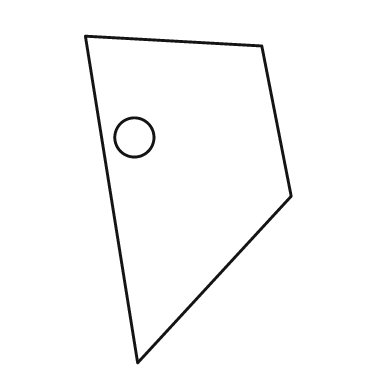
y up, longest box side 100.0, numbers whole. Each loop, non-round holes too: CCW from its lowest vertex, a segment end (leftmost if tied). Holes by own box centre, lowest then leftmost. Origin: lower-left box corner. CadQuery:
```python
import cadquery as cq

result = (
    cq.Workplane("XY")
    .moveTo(16.0, 0.0)
    .lineTo(63.0, 51.0)
    .lineTo(54.0, 97.0)
    .lineTo(0.0, 100.0)
    .close()
    .moveTo(15.0, 69.0)
    .circle(6.0)
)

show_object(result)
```